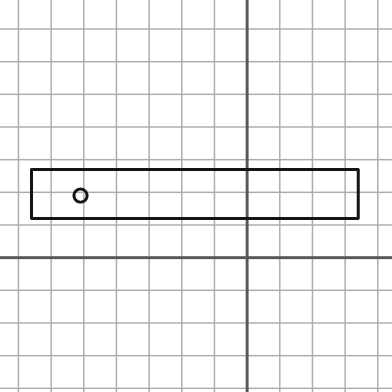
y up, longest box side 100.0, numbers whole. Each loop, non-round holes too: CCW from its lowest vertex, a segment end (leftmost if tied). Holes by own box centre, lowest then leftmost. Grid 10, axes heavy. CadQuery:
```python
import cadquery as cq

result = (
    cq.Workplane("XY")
    .moveTo(-66.0, 12.0)
    .lineTo(34.0, 12.0)
    .lineTo(34.0, 27.0)
    .lineTo(-66.0, 27.0)
    .close()
    .moveTo(-51.0, 19.0)
    .circle(2.0)
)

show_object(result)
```